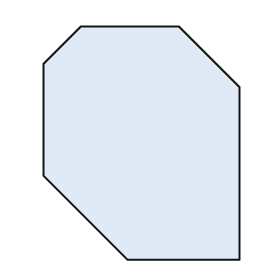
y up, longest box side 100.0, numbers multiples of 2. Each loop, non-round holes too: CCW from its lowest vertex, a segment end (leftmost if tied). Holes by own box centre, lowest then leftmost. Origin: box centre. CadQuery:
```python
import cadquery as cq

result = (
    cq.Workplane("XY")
    .moveTo(-6.0, -50.0)
    .lineTo(42.0, -50.0)
    .lineTo(42.0, 24.0)
    .lineTo(16.0, 50.0)
    .lineTo(-26.0, 50.0)
    .lineTo(-42.0, 34.0)
    .lineTo(-42.0, -14.0)
    .close()
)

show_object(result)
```